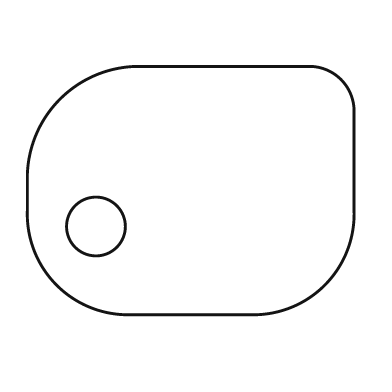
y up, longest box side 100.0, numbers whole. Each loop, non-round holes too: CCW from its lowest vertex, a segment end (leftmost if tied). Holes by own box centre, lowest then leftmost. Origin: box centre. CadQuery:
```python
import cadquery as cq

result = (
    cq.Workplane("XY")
    .moveTo(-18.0, -38.0)
    .lineTo(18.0, -38.0)
    .threePointArc((41.0, -29.0), (50.0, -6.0))
    .lineTo(50.0, 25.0)
    .threePointArc((46.0, 34.0), (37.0, 38.0))
    .lineTo(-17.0, 38.0)
    .threePointArc((-40.0, 28.0), (-50.0, 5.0))
    .lineTo(-50.0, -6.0)
    .threePointArc((-41.0, -29.0), (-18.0, -38.0))
    .close()
    .moveTo(-29.0, -11.0)
    .circle(9.0)
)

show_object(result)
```